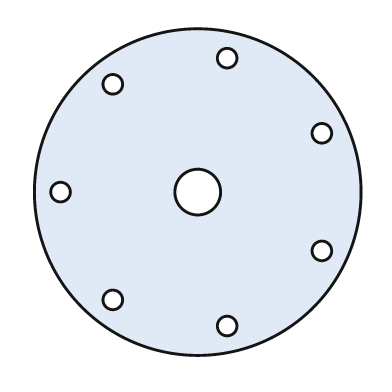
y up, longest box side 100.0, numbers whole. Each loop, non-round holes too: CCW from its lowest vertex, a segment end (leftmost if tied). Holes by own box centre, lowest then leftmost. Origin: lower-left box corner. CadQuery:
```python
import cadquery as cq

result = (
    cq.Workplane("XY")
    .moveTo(50.0, 50.0)
    .circle(50.0)
    .moveTo(59.0, 9.0)
    .circle(3.0)
    .moveTo(24.0, 17.0)
    .circle(3.0)
    .moveTo(88.0, 32.0)
    .circle(3.0)
    .moveTo(8.0, 50.0)
    .circle(3.0)
    .moveTo(50.0, 50.0)
    .circle(7.0)
    .moveTo(88.0, 68.0)
    .circle(3.0)
    .moveTo(24.0, 83.0)
    .circle(3.0)
    .moveTo(59.0, 91.0)
    .circle(3.0)
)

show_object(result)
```